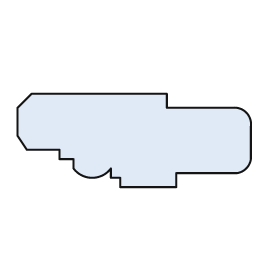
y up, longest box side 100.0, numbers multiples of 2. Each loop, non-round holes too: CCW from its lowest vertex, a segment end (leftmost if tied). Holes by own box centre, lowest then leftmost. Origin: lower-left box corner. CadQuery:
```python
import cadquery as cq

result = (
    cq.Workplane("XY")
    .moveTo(44.0, 0.0)
    .lineTo(68.0, 0.0)
    .lineTo(68.0, 6.0)
    .lineTo(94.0, 6.0)
    .threePointArc((98.0, 8.0), (100.0, 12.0))
    .lineTo(100.0, 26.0)
    .threePointArc((98.0, 32.0), (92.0, 34.0))
    .lineTo(64.0, 34.0)
    .lineTo(64.0, 40.0)
    .lineTo(6.0, 40.0)
    .lineTo(0.0, 34.0)
    .lineTo(0.0, 22.0)
    .lineTo(4.0, 16.0)
    .lineTo(18.0, 16.0)
    .lineTo(18.0, 12.0)
    .lineTo(24.0, 12.0)
    .lineTo(24.0, 8.0)
    .threePointArc((32.0, 4.0), (40.0, 8.0))
    .lineTo(40.0, 4.0)
    .lineTo(44.0, 4.0)
    .close()
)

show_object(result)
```